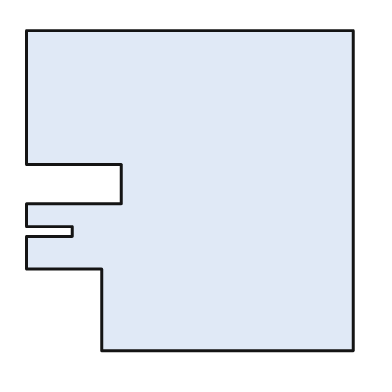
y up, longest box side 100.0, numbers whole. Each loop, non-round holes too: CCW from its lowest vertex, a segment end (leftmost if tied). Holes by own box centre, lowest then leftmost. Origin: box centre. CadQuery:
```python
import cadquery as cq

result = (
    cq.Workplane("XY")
    .moveTo(-27.0, -49.0)
    .lineTo(50.0, -49.0)
    .lineTo(50.0, 49.0)
    .lineTo(-50.0, 49.0)
    .lineTo(-50.0, 8.0)
    .lineTo(-21.0, 8.0)
    .lineTo(-21.0, -4.0)
    .lineTo(-50.0, -4.0)
    .lineTo(-50.0, -11.0)
    .lineTo(-36.0, -11.0)
    .lineTo(-36.0, -14.0)
    .lineTo(-50.0, -14.0)
    .lineTo(-50.0, -24.0)
    .lineTo(-27.0, -24.0)
    .close()
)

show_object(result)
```